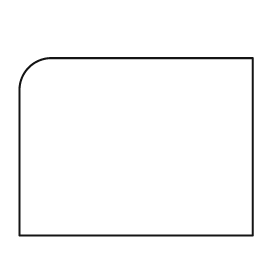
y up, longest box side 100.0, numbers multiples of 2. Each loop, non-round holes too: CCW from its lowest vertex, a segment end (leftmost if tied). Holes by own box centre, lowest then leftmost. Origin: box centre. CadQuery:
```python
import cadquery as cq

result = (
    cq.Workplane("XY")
    .moveTo(-50.0, -38.0)
    .lineTo(50.0, -38.0)
    .lineTo(50.0, 38.0)
    .lineTo(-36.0, 38.0)
    .threePointArc((-46.0, 34.0), (-50.0, 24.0))
    .close()
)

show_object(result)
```